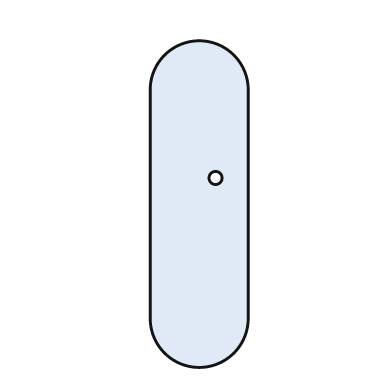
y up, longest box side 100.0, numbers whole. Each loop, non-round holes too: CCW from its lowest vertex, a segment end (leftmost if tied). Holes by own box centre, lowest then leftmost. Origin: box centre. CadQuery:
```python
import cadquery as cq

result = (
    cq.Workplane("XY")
    .moveTo(-15.0, -35.0)
    .threePointArc((0.0, -50.0), (15.0, -35.0))
    .lineTo(15.0, 35.0)
    .threePointArc((0.0, 50.0), (-15.0, 35.0))
    .close()
    .moveTo(5.0, 8.0)
    .circle(2.0)
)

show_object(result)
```